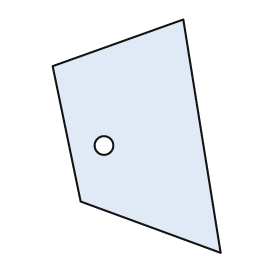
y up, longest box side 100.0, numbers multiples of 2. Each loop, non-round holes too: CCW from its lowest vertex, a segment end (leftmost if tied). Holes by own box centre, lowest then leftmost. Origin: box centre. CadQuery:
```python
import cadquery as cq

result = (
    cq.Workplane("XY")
    .moveTo(36.0, -50.0)
    .lineTo(20.0, 50.0)
    .lineTo(-36.0, 30.0)
    .lineTo(-24.0, -28.0)
    .close()
    .moveTo(-14.0, -4.0)
    .circle(4.0)
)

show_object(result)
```